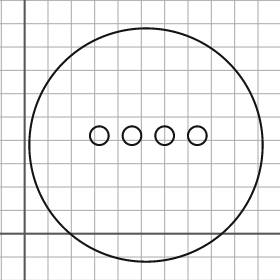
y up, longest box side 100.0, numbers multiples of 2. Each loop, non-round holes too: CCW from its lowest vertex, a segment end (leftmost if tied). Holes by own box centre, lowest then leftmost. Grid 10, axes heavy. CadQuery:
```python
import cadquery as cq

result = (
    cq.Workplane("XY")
    .moveTo(52.0, 38.0)
    .circle(50.0)
    .moveTo(32.0, 42.0)
    .circle(4.0)
    .moveTo(46.0, 42.0)
    .circle(4.0)
    .moveTo(60.0, 42.0)
    .circle(4.0)
    .moveTo(74.0, 42.0)
    .circle(4.0)
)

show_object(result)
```